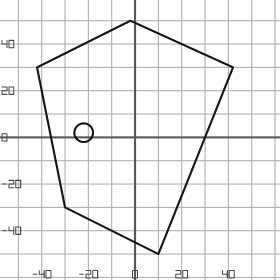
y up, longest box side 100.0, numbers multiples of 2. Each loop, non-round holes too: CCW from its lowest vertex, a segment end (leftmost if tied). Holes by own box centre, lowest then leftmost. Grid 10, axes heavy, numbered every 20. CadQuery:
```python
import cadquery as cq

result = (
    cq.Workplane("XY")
    .moveTo(10.0, -50.0)
    .lineTo(42.0, 30.0)
    .lineTo(-2.0, 50.0)
    .lineTo(-42.0, 30.0)
    .lineTo(-30.0, -30.0)
    .close()
    .moveTo(-22.0, 2.0)
    .circle(4.0)
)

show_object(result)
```